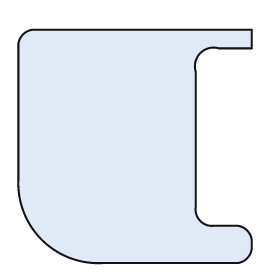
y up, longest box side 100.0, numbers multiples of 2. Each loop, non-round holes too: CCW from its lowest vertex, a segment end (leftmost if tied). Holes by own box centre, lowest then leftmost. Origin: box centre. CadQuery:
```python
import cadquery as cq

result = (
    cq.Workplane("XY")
    .moveTo(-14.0, -50.0)
    .lineTo(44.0, -50.0)
    .threePointArc((48.0, -48.0), (50.0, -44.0))
    .lineTo(50.0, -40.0)
    .threePointArc((48.0, -36.0), (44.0, -34.0))
    .lineTo(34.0, -34.0)
    .threePointArc((28.0, -32.0), (26.0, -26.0))
    .lineTo(26.0, 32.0)
    .threePointArc((28.0, 40.0), (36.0, 42.0))
    .lineTo(50.0, 42.0)
    .lineTo(50.0, 50.0)
    .lineTo(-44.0, 50.0)
    .threePointArc((-48.0, 48.0), (-50.0, 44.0))
    .lineTo(-50.0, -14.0)
    .threePointArc((-40.0, -40.0), (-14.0, -50.0))
    .close()
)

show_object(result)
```